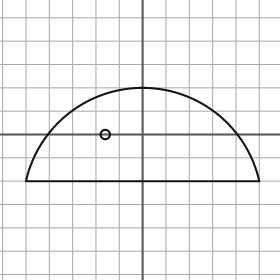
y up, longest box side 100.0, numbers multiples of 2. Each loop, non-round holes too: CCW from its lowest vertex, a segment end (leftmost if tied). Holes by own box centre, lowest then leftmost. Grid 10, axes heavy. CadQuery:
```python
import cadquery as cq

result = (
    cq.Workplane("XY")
    .moveTo(-50.0, -20.0)
    .lineTo(50.0, -20.0)
    .threePointArc((0.0, 20.0), (-50.0, -20.0))
    .close()
    .moveTo(-16.0, 0.0)
    .circle(2.0)
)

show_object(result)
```